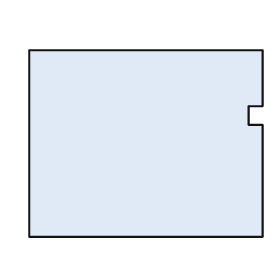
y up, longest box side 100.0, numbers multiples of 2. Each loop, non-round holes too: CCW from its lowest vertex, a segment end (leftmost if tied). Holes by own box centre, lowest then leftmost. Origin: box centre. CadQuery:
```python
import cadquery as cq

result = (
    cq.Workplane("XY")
    .moveTo(-50.0, -40.0)
    .lineTo(50.0, -40.0)
    .lineTo(50.0, 8.0)
    .lineTo(44.0, 8.0)
    .lineTo(44.0, 16.0)
    .lineTo(50.0, 16.0)
    .lineTo(50.0, 40.0)
    .lineTo(-50.0, 40.0)
    .close()
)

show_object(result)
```